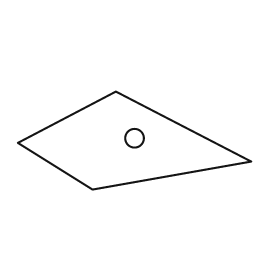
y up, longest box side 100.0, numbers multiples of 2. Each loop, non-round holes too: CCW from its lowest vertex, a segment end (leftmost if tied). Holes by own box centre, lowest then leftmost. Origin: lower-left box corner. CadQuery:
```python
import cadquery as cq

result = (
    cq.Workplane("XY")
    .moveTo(32.0, 0.0)
    .lineTo(100.0, 12.0)
    .lineTo(42.0, 42.0)
    .lineTo(0.0, 20.0)
    .close()
    .moveTo(50.0, 22.0)
    .circle(4.0)
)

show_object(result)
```